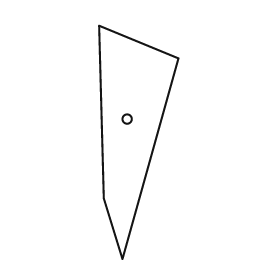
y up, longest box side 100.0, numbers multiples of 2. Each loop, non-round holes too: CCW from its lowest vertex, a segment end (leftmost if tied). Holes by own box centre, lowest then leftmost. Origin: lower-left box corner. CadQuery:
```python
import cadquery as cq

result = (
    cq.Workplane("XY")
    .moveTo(10.0, 0.0)
    .lineTo(34.0, 86.0)
    .lineTo(0.0, 100.0)
    .lineTo(2.0, 26.0)
    .close()
    .moveTo(12.0, 60.0)
    .circle(2.0)
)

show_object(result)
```